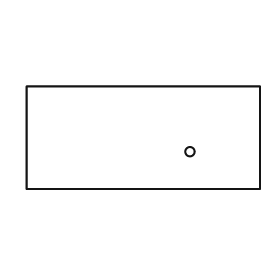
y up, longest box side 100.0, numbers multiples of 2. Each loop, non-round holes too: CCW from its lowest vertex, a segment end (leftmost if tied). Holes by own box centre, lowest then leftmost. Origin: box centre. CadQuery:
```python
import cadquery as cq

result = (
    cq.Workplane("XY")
    .moveTo(-50.0, -22.0)
    .lineTo(50.0, -22.0)
    .lineTo(50.0, 22.0)
    .lineTo(-50.0, 22.0)
    .close()
    .moveTo(20.0, -6.0)
    .circle(2.0)
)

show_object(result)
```